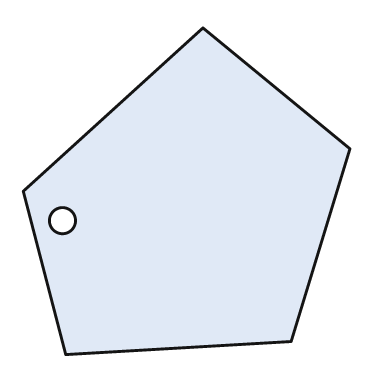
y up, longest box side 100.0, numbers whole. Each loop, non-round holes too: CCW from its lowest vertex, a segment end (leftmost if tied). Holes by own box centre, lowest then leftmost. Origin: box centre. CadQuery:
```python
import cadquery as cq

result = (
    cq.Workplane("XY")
    .moveTo(-37.0, -50.0)
    .lineTo(32.0, -46.0)
    .lineTo(50.0, 13.0)
    .lineTo(5.0, 50.0)
    .lineTo(-50.0, 0.0)
    .close()
    .moveTo(-38.0, -9.0)
    .circle(4.0)
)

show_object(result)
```